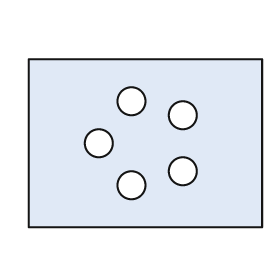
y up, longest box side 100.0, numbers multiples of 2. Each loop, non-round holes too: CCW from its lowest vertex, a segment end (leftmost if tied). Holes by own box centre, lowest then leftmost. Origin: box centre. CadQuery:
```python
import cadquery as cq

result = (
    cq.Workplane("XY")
    .moveTo(-50.0, -36.0)
    .lineTo(50.0, -36.0)
    .lineTo(50.0, 36.0)
    .lineTo(-50.0, 36.0)
    .close()
    .moveTo(-6.0, -18.0)
    .circle(6.0)
    .moveTo(16.0, -12.0)
    .circle(6.0)
    .moveTo(-20.0, 0.0)
    .circle(6.0)
    .moveTo(16.0, 12.0)
    .circle(6.0)
    .moveTo(-6.0, 18.0)
    .circle(6.0)
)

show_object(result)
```